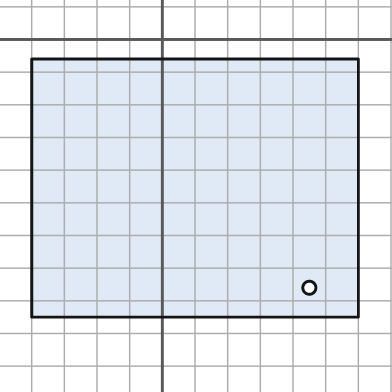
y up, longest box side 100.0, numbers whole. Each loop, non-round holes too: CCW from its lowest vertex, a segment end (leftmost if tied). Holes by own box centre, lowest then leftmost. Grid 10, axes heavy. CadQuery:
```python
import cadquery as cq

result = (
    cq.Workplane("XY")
    .moveTo(-40.0, -85.0)
    .lineTo(60.0, -85.0)
    .lineTo(60.0, -6.0)
    .lineTo(-40.0, -6.0)
    .close()
    .moveTo(45.0, -76.0)
    .circle(2.0)
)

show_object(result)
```